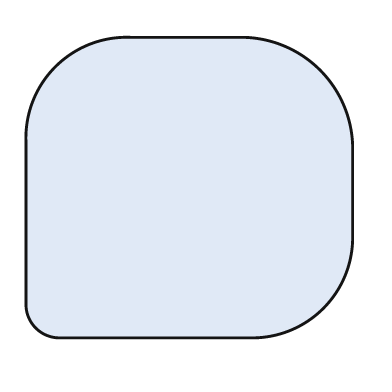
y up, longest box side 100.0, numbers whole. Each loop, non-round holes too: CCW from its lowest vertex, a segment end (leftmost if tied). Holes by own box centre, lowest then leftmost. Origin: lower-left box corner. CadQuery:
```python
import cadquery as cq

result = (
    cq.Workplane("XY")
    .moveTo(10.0, 0.0)
    .lineTo(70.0, 0.0)
    .threePointArc((91.0, 9.0), (100.0, 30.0))
    .lineTo(100.0, 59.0)
    .threePointArc((90.0, 82.0), (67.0, 92.0))
    .lineTo(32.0, 92.0)
    .threePointArc((9.0, 83.0), (0.0, 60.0))
    .lineTo(0.0, 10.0)
    .threePointArc((3.0, 3.0), (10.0, 0.0))
    .close()
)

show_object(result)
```